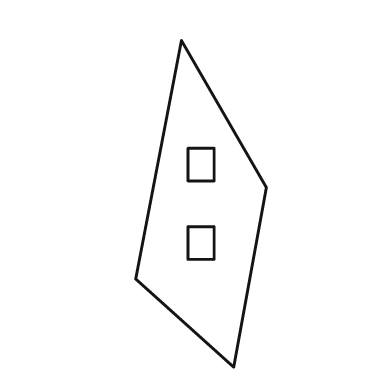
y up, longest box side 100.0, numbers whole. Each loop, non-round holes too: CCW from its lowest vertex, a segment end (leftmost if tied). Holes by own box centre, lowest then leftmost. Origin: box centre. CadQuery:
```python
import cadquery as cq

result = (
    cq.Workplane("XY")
    .moveTo(10.0, -50.0)
    .lineTo(20.0, 5.0)
    .lineTo(-6.0, 50.0)
    .lineTo(-20.0, -23.0)
    .close()
    .moveTo(-4.0, -17.0)
    .lineTo(4.0, -17.0)
    .lineTo(4.0, -7.0)
    .lineTo(-4.0, -7.0)
    .close()
    .moveTo(-4.0, 7.0)
    .lineTo(4.0, 7.0)
    .lineTo(4.0, 17.0)
    .lineTo(-4.0, 17.0)
    .close()
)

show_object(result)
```